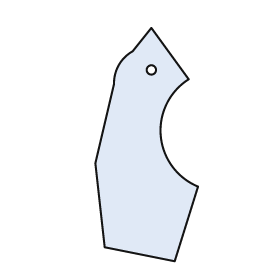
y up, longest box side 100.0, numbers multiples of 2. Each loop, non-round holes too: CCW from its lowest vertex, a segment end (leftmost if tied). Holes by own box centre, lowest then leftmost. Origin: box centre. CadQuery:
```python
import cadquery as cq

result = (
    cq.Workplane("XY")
    .moveTo(12.0, -50.0)
    .lineTo(22.0, -18.0)
    .threePointArc((6.0, 4.0), (18.0, 28.0))
    .lineTo(2.0, 50.0)
    .lineTo(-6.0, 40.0)
    .threePointArc((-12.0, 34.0), (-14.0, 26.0))
    .lineTo(-22.0, -8.0)
    .lineTo(-18.0, -44.0)
    .close()
    .moveTo(2.0, 32.0)
    .circle(2.0)
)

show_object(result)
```